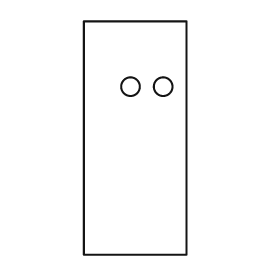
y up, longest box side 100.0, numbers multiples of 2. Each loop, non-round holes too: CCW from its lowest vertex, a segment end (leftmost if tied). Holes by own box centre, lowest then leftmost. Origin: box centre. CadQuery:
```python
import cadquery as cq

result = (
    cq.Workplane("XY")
    .moveTo(-22.0, -50.0)
    .lineTo(22.0, -50.0)
    .lineTo(22.0, 50.0)
    .lineTo(-22.0, 50.0)
    .close()
    .moveTo(-2.0, 22.0)
    .circle(4.0)
    .moveTo(12.0, 22.0)
    .circle(4.0)
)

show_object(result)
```